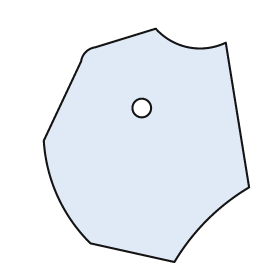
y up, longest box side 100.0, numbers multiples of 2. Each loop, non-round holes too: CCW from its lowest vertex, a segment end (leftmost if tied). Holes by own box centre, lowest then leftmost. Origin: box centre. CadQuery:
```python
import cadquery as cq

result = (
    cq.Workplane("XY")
    .moveTo(12.0, -50.0)
    .threePointArc((26.0, -32.0), (44.0, -18.0))
    .lineTo(34.0, 44.0)
    .threePointArc((18.0, 42.0), (4.0, 50.0))
    .lineTo(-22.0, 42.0)
    .threePointArc((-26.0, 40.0), (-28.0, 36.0))
    .lineTo(-44.0, 2.0)
    .threePointArc((-38.0, -22.0), (-24.0, -42.0))
    .close()
    .moveTo(-2.0, 16.0)
    .circle(4.0)
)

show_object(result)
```